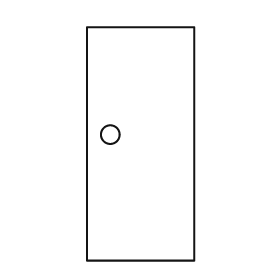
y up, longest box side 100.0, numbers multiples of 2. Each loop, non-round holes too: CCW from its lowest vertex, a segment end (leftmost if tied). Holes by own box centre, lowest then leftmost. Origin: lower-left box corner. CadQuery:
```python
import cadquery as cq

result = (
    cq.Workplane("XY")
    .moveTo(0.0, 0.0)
    .lineTo(46.0, 0.0)
    .lineTo(46.0, 100.0)
    .lineTo(0.0, 100.0)
    .close()
    .moveTo(10.0, 54.0)
    .circle(4.0)
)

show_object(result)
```